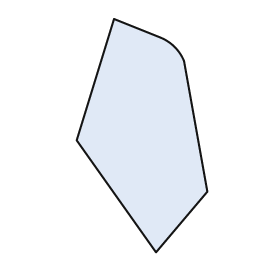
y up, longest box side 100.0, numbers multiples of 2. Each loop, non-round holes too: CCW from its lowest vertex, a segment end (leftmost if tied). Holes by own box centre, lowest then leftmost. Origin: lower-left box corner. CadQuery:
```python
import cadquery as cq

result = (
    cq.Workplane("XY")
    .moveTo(34.0, 0.0)
    .lineTo(56.0, 26.0)
    .lineTo(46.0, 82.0)
    .threePointArc((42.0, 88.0), (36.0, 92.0))
    .lineTo(16.0, 100.0)
    .lineTo(0.0, 48.0)
    .close()
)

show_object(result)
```